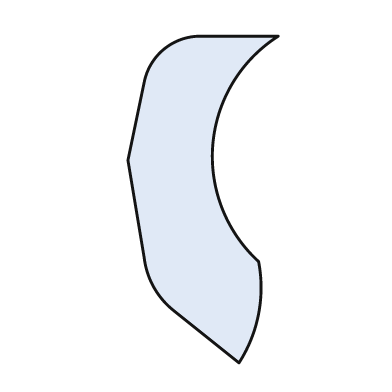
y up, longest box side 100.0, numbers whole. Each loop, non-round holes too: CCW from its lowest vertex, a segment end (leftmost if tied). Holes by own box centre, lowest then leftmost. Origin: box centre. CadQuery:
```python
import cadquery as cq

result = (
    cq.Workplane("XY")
    .moveTo(11.0, -50.0)
    .threePointArc((17.0, -35.0), (17.0, -19.0))
    .threePointArc((3.0, 17.0), (23.0, 50.0))
    .lineTo(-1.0, 50.0)
    .threePointArc((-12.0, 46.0), (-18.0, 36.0))
    .lineTo(-23.0, 12.0)
    .lineTo(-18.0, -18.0)
    .threePointArc((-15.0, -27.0), (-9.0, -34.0))
    .close()
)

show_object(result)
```